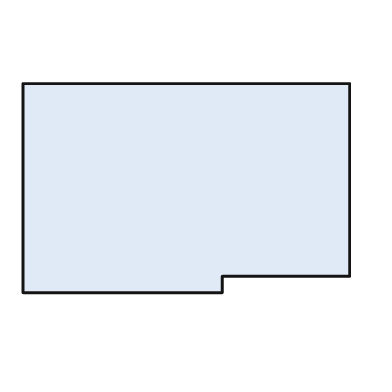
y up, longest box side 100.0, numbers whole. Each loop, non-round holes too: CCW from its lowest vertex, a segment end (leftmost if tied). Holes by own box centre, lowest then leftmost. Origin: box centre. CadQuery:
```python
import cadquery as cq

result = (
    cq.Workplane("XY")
    .moveTo(-50.0, -32.0)
    .lineTo(11.0, -32.0)
    .lineTo(11.0, -27.0)
    .lineTo(50.0, -27.0)
    .lineTo(50.0, 32.0)
    .lineTo(-50.0, 32.0)
    .close()
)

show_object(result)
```